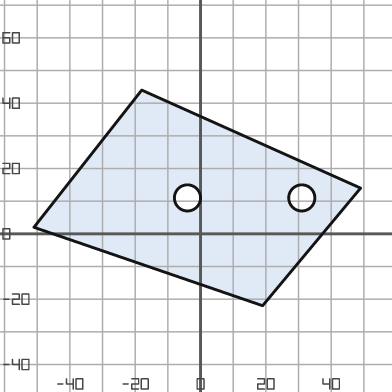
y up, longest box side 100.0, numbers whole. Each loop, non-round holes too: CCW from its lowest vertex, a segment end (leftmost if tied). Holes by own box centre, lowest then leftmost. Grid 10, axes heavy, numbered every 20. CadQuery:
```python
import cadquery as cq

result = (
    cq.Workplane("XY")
    .moveTo(19.0, -22.0)
    .lineTo(49.0, 14.0)
    .lineTo(-18.0, 44.0)
    .lineTo(-51.0, 2.0)
    .close()
    .moveTo(-4.0, 11.0)
    .circle(4.0)
    .moveTo(31.0, 11.0)
    .circle(4.0)
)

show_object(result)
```